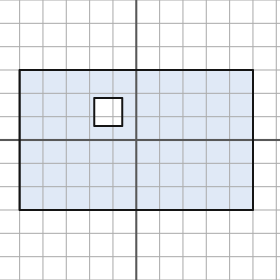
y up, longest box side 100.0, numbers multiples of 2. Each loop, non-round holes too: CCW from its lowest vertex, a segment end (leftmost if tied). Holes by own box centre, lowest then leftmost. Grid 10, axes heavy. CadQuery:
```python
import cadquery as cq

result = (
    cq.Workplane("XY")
    .moveTo(-50.0, -30.0)
    .lineTo(50.0, -30.0)
    .lineTo(50.0, 30.0)
    .lineTo(-50.0, 30.0)
    .close()
    .moveTo(-18.0, 6.0)
    .lineTo(-6.0, 6.0)
    .lineTo(-6.0, 18.0)
    .lineTo(-18.0, 18.0)
    .close()
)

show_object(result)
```